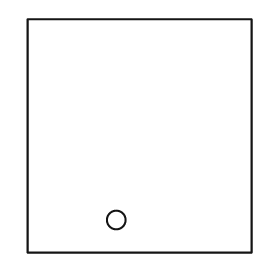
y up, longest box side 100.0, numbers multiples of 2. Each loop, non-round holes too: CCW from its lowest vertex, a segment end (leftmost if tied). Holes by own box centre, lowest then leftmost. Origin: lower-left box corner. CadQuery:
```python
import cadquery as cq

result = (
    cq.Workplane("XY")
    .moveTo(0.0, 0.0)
    .lineTo(96.0, 0.0)
    .lineTo(96.0, 100.0)
    .lineTo(0.0, 100.0)
    .close()
    .moveTo(38.0, 14.0)
    .circle(4.0)
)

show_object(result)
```